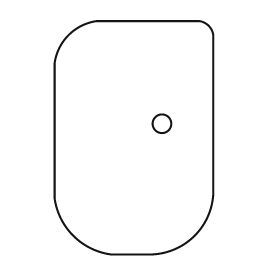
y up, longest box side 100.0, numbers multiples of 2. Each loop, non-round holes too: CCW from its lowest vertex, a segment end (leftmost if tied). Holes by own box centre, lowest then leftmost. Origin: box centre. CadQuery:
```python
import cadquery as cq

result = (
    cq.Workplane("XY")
    .moveTo(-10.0, -50.0)
    .lineTo(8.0, -50.0)
    .threePointArc((26.0, -42.0), (34.0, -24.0))
    .lineTo(34.0, 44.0)
    .threePointArc((32.0, 48.0), (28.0, 50.0))
    .lineTo(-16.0, 50.0)
    .threePointArc((-28.0, 44.0), (-34.0, 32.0))
    .lineTo(-34.0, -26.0)
    .threePointArc((-26.0, -42.0), (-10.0, -50.0))
    .close()
    .moveTo(12.0, 6.0)
    .circle(4.0)
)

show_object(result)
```